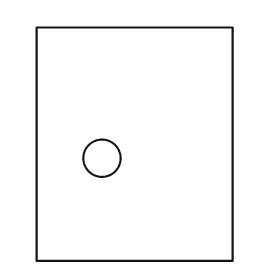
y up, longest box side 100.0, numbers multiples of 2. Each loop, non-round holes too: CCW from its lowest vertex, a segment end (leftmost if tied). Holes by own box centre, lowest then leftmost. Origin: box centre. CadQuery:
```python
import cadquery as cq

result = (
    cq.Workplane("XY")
    .moveTo(-42.0, -50.0)
    .lineTo(42.0, -50.0)
    .lineTo(42.0, 50.0)
    .lineTo(-42.0, 50.0)
    .close()
    .moveTo(-14.0, -6.0)
    .circle(8.0)
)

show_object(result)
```